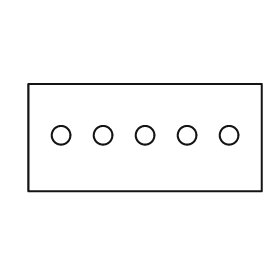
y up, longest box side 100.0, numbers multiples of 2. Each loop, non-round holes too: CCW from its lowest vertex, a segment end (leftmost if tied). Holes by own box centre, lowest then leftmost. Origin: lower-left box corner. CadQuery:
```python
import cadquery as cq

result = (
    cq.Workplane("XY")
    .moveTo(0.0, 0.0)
    .lineTo(100.0, 0.0)
    .lineTo(100.0, 46.0)
    .lineTo(0.0, 46.0)
    .close()
    .moveTo(14.0, 24.0)
    .circle(4.0)
    .moveTo(32.0, 24.0)
    .circle(4.0)
    .moveTo(50.0, 24.0)
    .circle(4.0)
    .moveTo(68.0, 24.0)
    .circle(4.0)
    .moveTo(86.0, 24.0)
    .circle(4.0)
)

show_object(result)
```